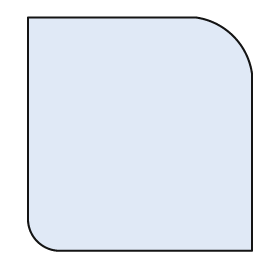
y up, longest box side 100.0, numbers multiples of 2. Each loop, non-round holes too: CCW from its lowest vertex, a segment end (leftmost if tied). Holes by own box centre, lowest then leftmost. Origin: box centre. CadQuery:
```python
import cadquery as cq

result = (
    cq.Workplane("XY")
    .moveTo(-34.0, -50.0)
    .lineTo(48.0, -50.0)
    .lineTo(48.0, 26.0)
    .threePointArc((40.0, 42.0), (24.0, 50.0))
    .lineTo(-48.0, 50.0)
    .lineTo(-48.0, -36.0)
    .threePointArc((-44.0, -46.0), (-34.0, -50.0))
    .close()
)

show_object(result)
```